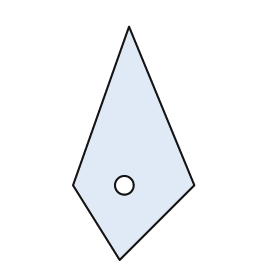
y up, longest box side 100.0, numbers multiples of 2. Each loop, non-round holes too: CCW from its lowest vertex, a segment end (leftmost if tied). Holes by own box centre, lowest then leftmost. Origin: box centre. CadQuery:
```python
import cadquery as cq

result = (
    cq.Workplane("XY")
    .moveTo(-6.0, -50.0)
    .lineTo(26.0, -18.0)
    .lineTo(-2.0, 50.0)
    .lineTo(-26.0, -18.0)
    .close()
    .moveTo(-4.0, -18.0)
    .circle(4.0)
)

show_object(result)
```